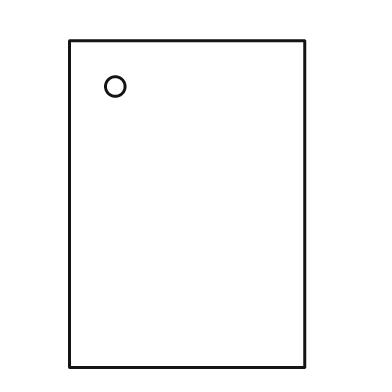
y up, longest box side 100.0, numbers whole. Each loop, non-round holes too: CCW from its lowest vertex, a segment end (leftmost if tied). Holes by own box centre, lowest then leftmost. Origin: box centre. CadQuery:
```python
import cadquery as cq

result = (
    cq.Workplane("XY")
    .moveTo(-36.0, -50.0)
    .lineTo(36.0, -50.0)
    .lineTo(36.0, 50.0)
    .lineTo(-36.0, 50.0)
    .close()
    .moveTo(-22.0, 36.0)
    .circle(3.0)
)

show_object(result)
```